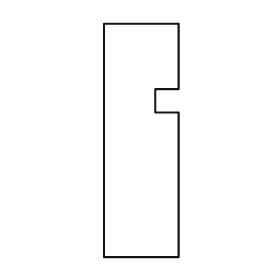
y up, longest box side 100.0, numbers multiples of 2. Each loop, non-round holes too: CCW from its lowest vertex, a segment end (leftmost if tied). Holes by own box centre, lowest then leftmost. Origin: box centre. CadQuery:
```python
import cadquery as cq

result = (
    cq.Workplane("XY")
    .moveTo(-16.0, -50.0)
    .lineTo(16.0, -50.0)
    .lineTo(16.0, 12.0)
    .lineTo(6.0, 12.0)
    .lineTo(6.0, 22.0)
    .lineTo(16.0, 22.0)
    .lineTo(16.0, 50.0)
    .lineTo(-16.0, 50.0)
    .close()
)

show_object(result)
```